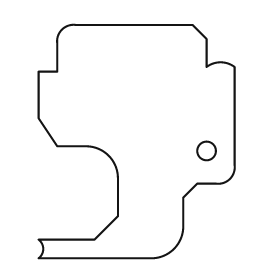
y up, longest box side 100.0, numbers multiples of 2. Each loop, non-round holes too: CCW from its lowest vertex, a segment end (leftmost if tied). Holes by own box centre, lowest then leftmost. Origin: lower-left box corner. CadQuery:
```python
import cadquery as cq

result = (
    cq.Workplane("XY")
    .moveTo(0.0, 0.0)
    .lineTo(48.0, 0.0)
    .threePointArc((58.0, 4.0), (62.0, 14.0))
    .lineTo(62.0, 26.0)
    .lineTo(68.0, 32.0)
    .lineTo(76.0, 32.0)
    .threePointArc((82.0, 34.0), (84.0, 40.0))
    .lineTo(84.0, 82.0)
    .threePointArc((78.0, 84.0), (72.0, 82.0))
    .lineTo(72.0, 94.0)
    .lineTo(66.0, 100.0)
    .lineTo(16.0, 100.0)
    .threePointArc((10.0, 98.0), (8.0, 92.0))
    .lineTo(8.0, 80.0)
    .lineTo(0.0, 80.0)
    .lineTo(0.0, 60.0)
    .lineTo(8.0, 48.0)
    .lineTo(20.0, 48.0)
    .threePointArc((30.0, 44.0), (34.0, 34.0))
    .lineTo(34.0, 18.0)
    .lineTo(24.0, 8.0)
    .lineTo(0.0, 8.0)
    .threePointArc((2.0, 4.0), (0.0, 0.0))
    .close()
    .moveTo(72.0, 46.0)
    .circle(4.0)
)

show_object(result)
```